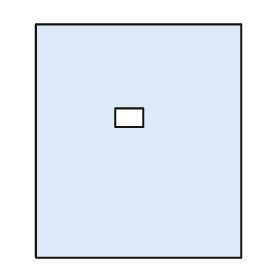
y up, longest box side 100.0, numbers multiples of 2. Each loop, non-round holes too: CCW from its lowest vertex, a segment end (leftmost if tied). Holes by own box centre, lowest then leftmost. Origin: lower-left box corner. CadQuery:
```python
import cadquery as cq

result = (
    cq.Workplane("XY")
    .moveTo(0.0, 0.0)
    .lineTo(88.0, 0.0)
    .lineTo(88.0, 100.0)
    .lineTo(0.0, 100.0)
    .close()
    .moveTo(34.0, 56.0)
    .lineTo(46.0, 56.0)
    .lineTo(46.0, 64.0)
    .lineTo(34.0, 64.0)
    .close()
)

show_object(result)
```